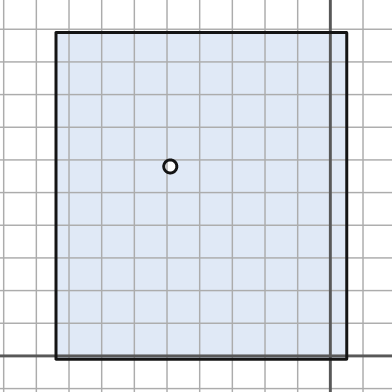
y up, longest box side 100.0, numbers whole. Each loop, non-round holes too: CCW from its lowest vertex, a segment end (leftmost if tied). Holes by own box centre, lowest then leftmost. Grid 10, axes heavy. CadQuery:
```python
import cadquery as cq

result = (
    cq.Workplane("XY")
    .moveTo(-84.0, -1.0)
    .lineTo(5.0, -1.0)
    .lineTo(5.0, 99.0)
    .lineTo(-84.0, 99.0)
    .close()
    .moveTo(-49.0, 58.0)
    .circle(2.0)
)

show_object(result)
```